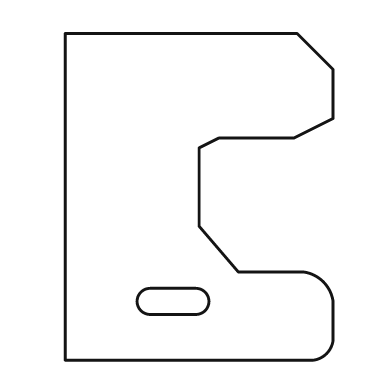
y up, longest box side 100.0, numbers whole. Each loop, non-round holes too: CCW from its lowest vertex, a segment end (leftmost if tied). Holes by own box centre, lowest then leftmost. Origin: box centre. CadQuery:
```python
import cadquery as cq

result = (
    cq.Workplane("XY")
    .moveTo(-41.0, -50.0)
    .lineTo(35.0, -50.0)
    .threePointArc((39.0, -48.0), (41.0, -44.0))
    .lineTo(41.0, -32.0)
    .threePointArc((38.0, -26.0), (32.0, -23.0))
    .lineTo(12.0, -23.0)
    .lineTo(0.0, -9.0)
    .lineTo(0.0, 15.0)
    .lineTo(6.0, 18.0)
    .lineTo(29.0, 18.0)
    .lineTo(41.0, 24.0)
    .lineTo(41.0, 39.0)
    .lineTo(30.0, 50.0)
    .lineTo(-41.0, 50.0)
    .close()
    .moveTo(-15.0, -36.0)
    .lineTo(-1.0, -36.0)
    .threePointArc((3.0, -32.0), (-1.0, -28.0))
    .lineTo(-15.0, -28.0)
    .threePointArc((-19.0, -32.0), (-15.0, -36.0))
    .close()
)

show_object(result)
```